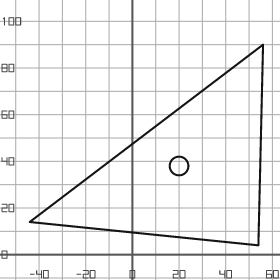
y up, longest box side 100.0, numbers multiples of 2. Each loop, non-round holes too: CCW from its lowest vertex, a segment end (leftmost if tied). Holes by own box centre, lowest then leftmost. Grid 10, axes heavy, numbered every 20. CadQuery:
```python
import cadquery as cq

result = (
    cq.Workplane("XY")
    .moveTo(54.0, 4.0)
    .lineTo(56.0, 90.0)
    .lineTo(-44.0, 14.0)
    .close()
    .moveTo(20.0, 38.0)
    .circle(4.0)
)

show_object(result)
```